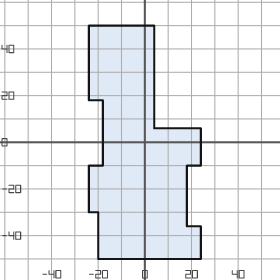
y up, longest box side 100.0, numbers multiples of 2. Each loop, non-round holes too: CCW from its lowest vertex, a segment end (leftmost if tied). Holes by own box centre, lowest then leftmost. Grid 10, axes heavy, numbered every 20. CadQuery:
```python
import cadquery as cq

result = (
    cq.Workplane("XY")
    .moveTo(-20.0, -50.0)
    .lineTo(24.0, -50.0)
    .lineTo(24.0, -36.0)
    .lineTo(18.0, -36.0)
    .lineTo(18.0, -10.0)
    .lineTo(24.0, -10.0)
    .lineTo(24.0, 6.0)
    .lineTo(4.0, 6.0)
    .lineTo(4.0, 50.0)
    .lineTo(-24.0, 50.0)
    .lineTo(-24.0, 18.0)
    .lineTo(-18.0, 18.0)
    .lineTo(-18.0, -10.0)
    .lineTo(-24.0, -10.0)
    .lineTo(-24.0, -30.0)
    .lineTo(-20.0, -30.0)
    .close()
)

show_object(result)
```